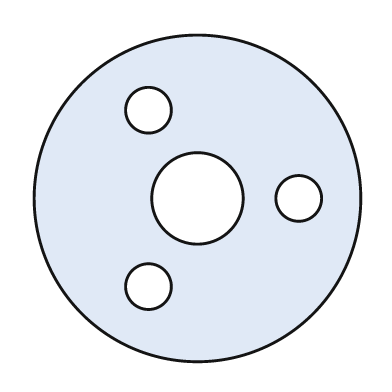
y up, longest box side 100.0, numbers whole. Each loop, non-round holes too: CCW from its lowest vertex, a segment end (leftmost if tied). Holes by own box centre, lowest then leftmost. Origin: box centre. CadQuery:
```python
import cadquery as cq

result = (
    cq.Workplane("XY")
    .moveTo(0.0, 0.0)
    .circle(50.0)
    .moveTo(-15.0, -27.0)
    .circle(7.0)
    .moveTo(0.0, 0.0)
    .circle(14.0)
    .moveTo(31.0, 0.0)
    .circle(7.0)
    .moveTo(-15.0, 27.0)
    .circle(7.0)
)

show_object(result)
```